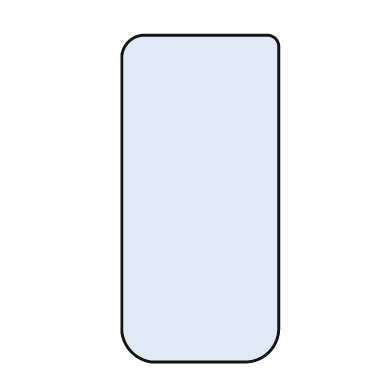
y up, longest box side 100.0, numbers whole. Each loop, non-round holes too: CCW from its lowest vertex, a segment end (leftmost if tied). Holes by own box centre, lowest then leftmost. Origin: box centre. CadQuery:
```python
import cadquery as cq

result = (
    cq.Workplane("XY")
    .moveTo(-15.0, -50.0)
    .lineTo(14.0, -50.0)
    .threePointArc((21.0, -47.0), (24.0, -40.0))
    .lineTo(24.0, 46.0)
    .threePointArc((23.0, 49.0), (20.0, 50.0))
    .lineTo(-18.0, 50.0)
    .threePointArc((-22.0, 48.0), (-24.0, 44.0))
    .lineTo(-24.0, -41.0)
    .threePointArc((-21.0, -47.0), (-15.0, -50.0))
    .close()
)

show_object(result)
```